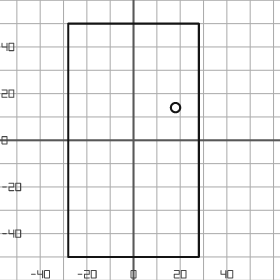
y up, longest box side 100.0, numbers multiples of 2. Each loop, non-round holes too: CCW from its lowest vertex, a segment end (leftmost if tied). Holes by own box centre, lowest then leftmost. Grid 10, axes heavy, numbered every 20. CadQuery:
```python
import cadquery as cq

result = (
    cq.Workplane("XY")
    .moveTo(-28.0, -50.0)
    .lineTo(28.0, -50.0)
    .lineTo(28.0, 50.0)
    .lineTo(-28.0, 50.0)
    .close()
    .moveTo(18.0, 14.0)
    .circle(2.0)
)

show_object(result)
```